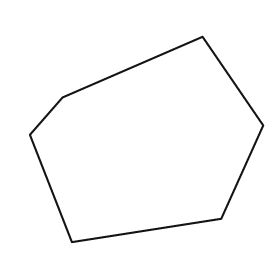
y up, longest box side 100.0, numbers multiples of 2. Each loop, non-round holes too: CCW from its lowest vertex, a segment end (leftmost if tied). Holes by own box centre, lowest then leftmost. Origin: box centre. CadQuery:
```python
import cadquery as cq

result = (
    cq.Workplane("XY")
    .moveTo(-32.0, -44.0)
    .lineTo(32.0, -34.0)
    .lineTo(50.0, 6.0)
    .lineTo(24.0, 44.0)
    .lineTo(-36.0, 18.0)
    .lineTo(-50.0, 2.0)
    .close()
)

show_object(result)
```